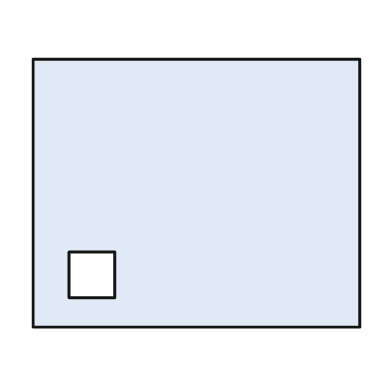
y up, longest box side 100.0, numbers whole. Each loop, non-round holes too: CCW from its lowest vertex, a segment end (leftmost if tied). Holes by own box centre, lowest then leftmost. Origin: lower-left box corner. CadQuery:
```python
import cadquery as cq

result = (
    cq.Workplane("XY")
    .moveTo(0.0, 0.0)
    .lineTo(100.0, 0.0)
    .lineTo(100.0, 82.0)
    .lineTo(0.0, 82.0)
    .close()
    .moveTo(11.0, 9.0)
    .lineTo(25.0, 9.0)
    .lineTo(25.0, 23.0)
    .lineTo(11.0, 23.0)
    .close()
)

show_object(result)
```